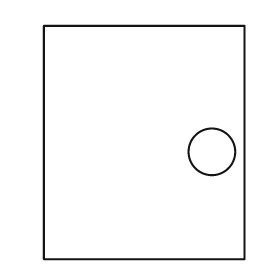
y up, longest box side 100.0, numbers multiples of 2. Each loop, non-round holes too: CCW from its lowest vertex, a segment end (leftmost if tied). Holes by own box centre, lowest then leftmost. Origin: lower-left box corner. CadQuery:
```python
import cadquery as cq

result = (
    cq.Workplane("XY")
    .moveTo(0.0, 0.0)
    .lineTo(86.0, 0.0)
    .lineTo(86.0, 100.0)
    .lineTo(0.0, 100.0)
    .close()
    .moveTo(72.0, 46.0)
    .circle(10.0)
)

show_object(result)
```